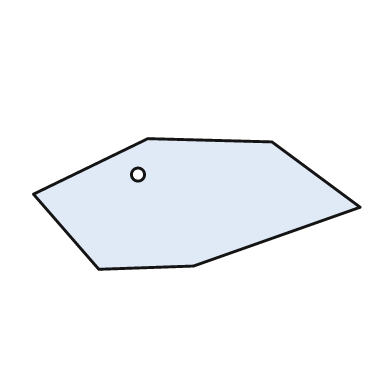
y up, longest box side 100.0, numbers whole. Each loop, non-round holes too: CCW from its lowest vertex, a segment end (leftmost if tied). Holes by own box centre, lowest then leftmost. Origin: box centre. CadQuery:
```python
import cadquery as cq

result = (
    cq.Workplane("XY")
    .moveTo(-30.0, -20.0)
    .lineTo(-1.0, -19.0)
    .lineTo(50.0, -1.0)
    .lineTo(23.0, 19.0)
    .lineTo(-15.0, 20.0)
    .lineTo(-50.0, 3.0)
    .close()
    .moveTo(-18.0, 9.0)
    .circle(2.0)
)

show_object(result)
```